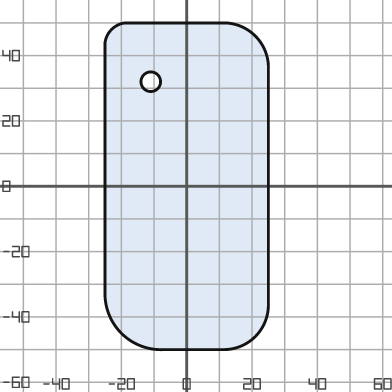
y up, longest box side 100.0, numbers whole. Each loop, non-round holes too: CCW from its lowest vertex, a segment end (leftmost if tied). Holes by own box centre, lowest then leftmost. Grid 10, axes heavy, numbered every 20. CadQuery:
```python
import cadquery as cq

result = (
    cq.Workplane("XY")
    .moveTo(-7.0, -50.0)
    .lineTo(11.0, -50.0)
    .threePointArc((21.0, -46.0), (25.0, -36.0))
    .lineTo(25.0, 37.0)
    .threePointArc((21.0, 46.0), (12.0, 50.0))
    .lineTo(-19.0, 50.0)
    .threePointArc((-23.0, 48.0), (-25.0, 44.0))
    .lineTo(-25.0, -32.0)
    .threePointArc((-20.0, -45.0), (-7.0, -50.0))
    .close()
    .moveTo(-11.0, 32.0)
    .circle(3.0)
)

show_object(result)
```